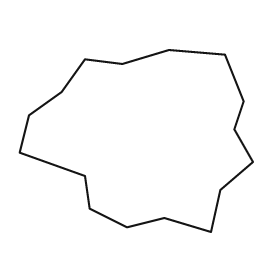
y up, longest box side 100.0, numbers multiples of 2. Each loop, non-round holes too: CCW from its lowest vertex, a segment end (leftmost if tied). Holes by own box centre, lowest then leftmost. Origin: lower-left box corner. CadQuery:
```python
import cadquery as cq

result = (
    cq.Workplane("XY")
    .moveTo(82.0, 0.0)
    .lineTo(86.0, 18.0)
    .lineTo(100.0, 30.0)
    .lineTo(92.0, 44.0)
    .lineTo(96.0, 56.0)
    .lineTo(88.0, 76.0)
    .lineTo(64.0, 78.0)
    .lineTo(44.0, 72.0)
    .lineTo(28.0, 74.0)
    .lineTo(18.0, 60.0)
    .lineTo(4.0, 50.0)
    .lineTo(0.0, 34.0)
    .lineTo(28.0, 24.0)
    .lineTo(30.0, 10.0)
    .lineTo(46.0, 2.0)
    .lineTo(62.0, 6.0)
    .close()
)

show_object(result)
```